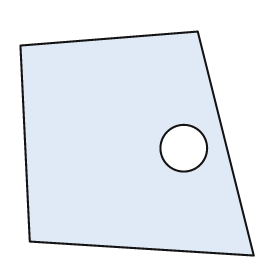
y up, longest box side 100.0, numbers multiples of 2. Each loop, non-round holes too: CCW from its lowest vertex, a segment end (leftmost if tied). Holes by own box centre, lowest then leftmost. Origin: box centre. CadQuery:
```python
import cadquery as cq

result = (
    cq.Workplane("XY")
    .moveTo(50.0, -48.0)
    .lineTo(26.0, 48.0)
    .lineTo(-50.0, 42.0)
    .lineTo(-46.0, -42.0)
    .close()
    .moveTo(20.0, -2.0)
    .circle(10.0)
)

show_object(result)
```